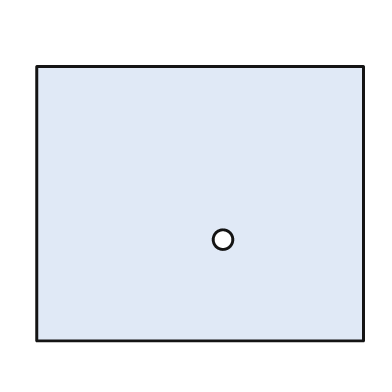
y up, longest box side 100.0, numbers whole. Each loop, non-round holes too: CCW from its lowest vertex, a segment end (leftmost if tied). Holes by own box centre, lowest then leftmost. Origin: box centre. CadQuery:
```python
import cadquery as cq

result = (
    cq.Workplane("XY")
    .moveTo(-50.0, -42.0)
    .lineTo(50.0, -42.0)
    .lineTo(50.0, 42.0)
    .lineTo(-50.0, 42.0)
    .close()
    .moveTo(7.0, -11.0)
    .circle(3.0)
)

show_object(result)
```